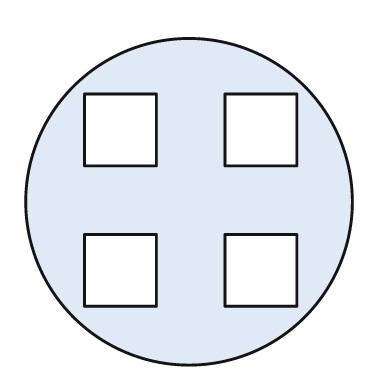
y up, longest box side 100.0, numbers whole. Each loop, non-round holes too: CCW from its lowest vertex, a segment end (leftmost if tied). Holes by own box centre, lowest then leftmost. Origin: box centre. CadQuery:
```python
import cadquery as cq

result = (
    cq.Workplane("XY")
    .moveTo(0.0, 0.0)
    .circle(50.0)
    .moveTo(-32.0, -32.0)
    .lineTo(-10.0, -32.0)
    .lineTo(-10.0, -10.0)
    .lineTo(-32.0, -10.0)
    .close()
    .moveTo(11.0, -32.0)
    .lineTo(33.0, -32.0)
    .lineTo(33.0, -10.0)
    .lineTo(11.0, -10.0)
    .close()
    .moveTo(-32.0, 11.0)
    .lineTo(-10.0, 11.0)
    .lineTo(-10.0, 33.0)
    .lineTo(-32.0, 33.0)
    .close()
    .moveTo(11.0, 11.0)
    .lineTo(33.0, 11.0)
    .lineTo(33.0, 33.0)
    .lineTo(11.0, 33.0)
    .close()
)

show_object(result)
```